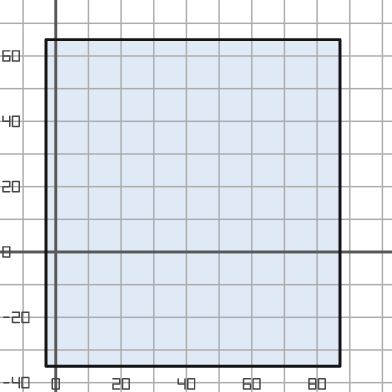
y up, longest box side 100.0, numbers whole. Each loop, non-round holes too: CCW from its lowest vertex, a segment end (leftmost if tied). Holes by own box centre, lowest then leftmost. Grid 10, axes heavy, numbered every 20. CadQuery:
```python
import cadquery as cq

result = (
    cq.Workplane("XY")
    .moveTo(-3.0, -35.0)
    .lineTo(87.0, -35.0)
    .lineTo(87.0, 65.0)
    .lineTo(-3.0, 65.0)
    .close()
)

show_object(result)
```